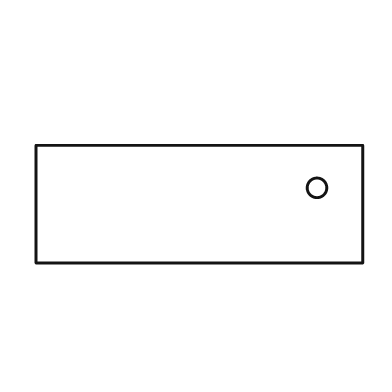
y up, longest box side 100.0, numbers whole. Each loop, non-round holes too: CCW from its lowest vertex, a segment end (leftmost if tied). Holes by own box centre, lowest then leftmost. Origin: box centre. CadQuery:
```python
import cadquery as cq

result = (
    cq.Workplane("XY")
    .moveTo(-50.0, -18.0)
    .lineTo(50.0, -18.0)
    .lineTo(50.0, 18.0)
    .lineTo(-50.0, 18.0)
    .close()
    .moveTo(36.0, 5.0)
    .circle(3.0)
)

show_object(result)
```